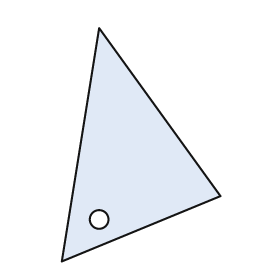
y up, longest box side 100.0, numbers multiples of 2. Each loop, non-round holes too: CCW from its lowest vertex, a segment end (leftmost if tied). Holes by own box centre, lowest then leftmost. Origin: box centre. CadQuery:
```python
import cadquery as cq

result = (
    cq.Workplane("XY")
    .moveTo(-34.0, -50.0)
    .lineTo(34.0, -22.0)
    .lineTo(-18.0, 50.0)
    .close()
    .moveTo(-18.0, -32.0)
    .circle(4.0)
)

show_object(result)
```